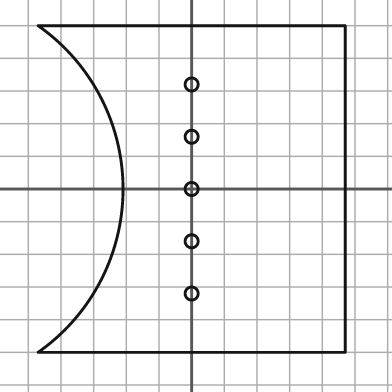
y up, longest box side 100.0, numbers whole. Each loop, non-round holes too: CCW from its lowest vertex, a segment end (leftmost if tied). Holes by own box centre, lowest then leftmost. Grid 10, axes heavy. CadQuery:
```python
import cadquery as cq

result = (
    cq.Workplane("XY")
    .moveTo(-47.0, -50.0)
    .lineTo(47.0, -50.0)
    .lineTo(47.0, 50.0)
    .lineTo(-47.0, 50.0)
    .threePointArc((-21.0, 0.0), (-47.0, -50.0))
    .close()
    .moveTo(0.0, -32.0)
    .circle(2.0)
    .moveTo(0.0, -16.0)
    .circle(2.0)
    .moveTo(0.0, 0.0)
    .circle(2.0)
    .moveTo(0.0, 16.0)
    .circle(2.0)
    .moveTo(0.0, 32.0)
    .circle(2.0)
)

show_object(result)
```